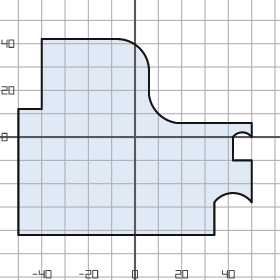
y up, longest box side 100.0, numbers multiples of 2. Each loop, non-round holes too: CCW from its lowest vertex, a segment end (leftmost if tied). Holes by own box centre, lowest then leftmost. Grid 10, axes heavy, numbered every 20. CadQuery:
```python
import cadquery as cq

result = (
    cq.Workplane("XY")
    .moveTo(-50.0, -42.0)
    .lineTo(34.0, -42.0)
    .lineTo(34.0, -28.0)
    .threePointArc((42.0, -24.0), (50.0, -28.0))
    .lineTo(50.0, -10.0)
    .lineTo(42.0, -10.0)
    .lineTo(42.0, 0.0)
    .threePointArc((46.0, 2.0), (50.0, 0.0))
    .lineTo(50.0, 6.0)
    .lineTo(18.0, 6.0)
    .threePointArc((10.0, 10.0), (6.0, 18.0))
    .lineTo(6.0, 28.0)
    .threePointArc((2.0, 38.0), (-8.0, 42.0))
    .lineTo(-40.0, 42.0)
    .lineTo(-40.0, 12.0)
    .lineTo(-50.0, 12.0)
    .close()
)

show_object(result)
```